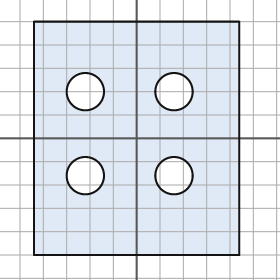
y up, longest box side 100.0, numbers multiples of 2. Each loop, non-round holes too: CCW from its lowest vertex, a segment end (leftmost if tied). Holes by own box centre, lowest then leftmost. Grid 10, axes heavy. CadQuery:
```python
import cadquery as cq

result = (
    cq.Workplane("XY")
    .moveTo(-44.0, -50.0)
    .lineTo(44.0, -50.0)
    .lineTo(44.0, 50.0)
    .lineTo(-44.0, 50.0)
    .close()
    .moveTo(-22.0, -16.0)
    .circle(8.0)
    .moveTo(16.0, -16.0)
    .circle(8.0)
    .moveTo(-22.0, 20.0)
    .circle(8.0)
    .moveTo(16.0, 20.0)
    .circle(8.0)
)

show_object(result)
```